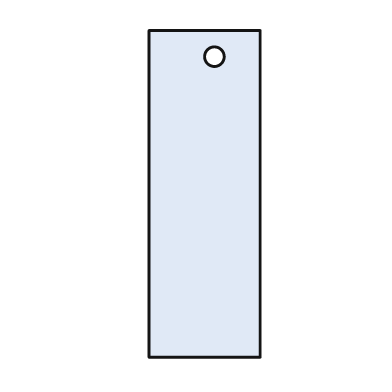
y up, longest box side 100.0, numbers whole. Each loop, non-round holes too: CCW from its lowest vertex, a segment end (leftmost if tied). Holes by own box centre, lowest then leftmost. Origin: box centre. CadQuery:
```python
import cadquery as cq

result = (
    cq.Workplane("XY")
    .moveTo(-17.0, -50.0)
    .lineTo(17.0, -50.0)
    .lineTo(17.0, 50.0)
    .lineTo(-17.0, 50.0)
    .close()
    .moveTo(3.0, 42.0)
    .circle(3.0)
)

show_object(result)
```